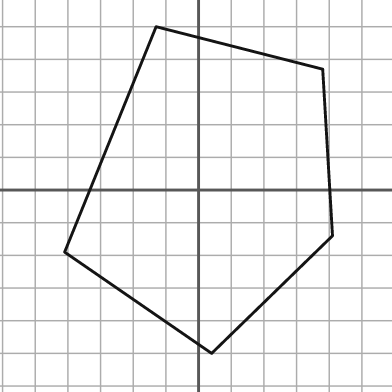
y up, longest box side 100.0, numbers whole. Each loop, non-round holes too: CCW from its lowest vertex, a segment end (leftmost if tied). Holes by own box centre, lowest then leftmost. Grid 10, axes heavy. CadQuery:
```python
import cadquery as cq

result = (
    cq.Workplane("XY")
    .moveTo(4.0, -50.0)
    .lineTo(41.0, -14.0)
    .lineTo(38.0, 37.0)
    .lineTo(-13.0, 50.0)
    .lineTo(-41.0, -19.0)
    .close()
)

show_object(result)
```